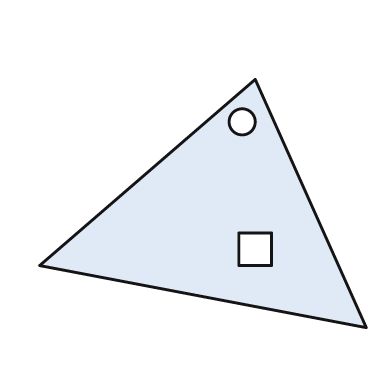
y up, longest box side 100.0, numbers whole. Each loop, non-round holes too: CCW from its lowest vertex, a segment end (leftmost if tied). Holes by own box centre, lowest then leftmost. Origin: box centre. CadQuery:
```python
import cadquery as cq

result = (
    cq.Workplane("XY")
    .moveTo(50.0, -38.0)
    .lineTo(16.0, 38.0)
    .lineTo(-50.0, -19.0)
    .close()
    .moveTo(11.0, -19.0)
    .lineTo(21.0, -19.0)
    .lineTo(21.0, -9.0)
    .lineTo(11.0, -9.0)
    .close()
    .moveTo(12.0, 25.0)
    .circle(4.0)
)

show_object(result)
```